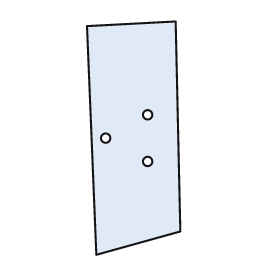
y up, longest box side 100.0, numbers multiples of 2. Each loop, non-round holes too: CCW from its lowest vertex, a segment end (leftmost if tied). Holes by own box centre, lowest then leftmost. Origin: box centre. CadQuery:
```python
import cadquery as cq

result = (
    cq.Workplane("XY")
    .moveTo(-16.0, -50.0)
    .lineTo(20.0, -40.0)
    .lineTo(18.0, 50.0)
    .lineTo(-20.0, 48.0)
    .close()
    .moveTo(6.0, -10.0)
    .circle(2.0)
    .moveTo(-12.0, 0.0)
    .circle(2.0)
    .moveTo(6.0, 10.0)
    .circle(2.0)
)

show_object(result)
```